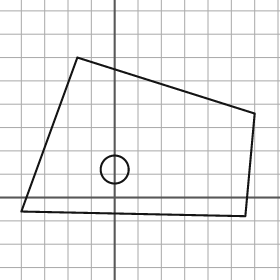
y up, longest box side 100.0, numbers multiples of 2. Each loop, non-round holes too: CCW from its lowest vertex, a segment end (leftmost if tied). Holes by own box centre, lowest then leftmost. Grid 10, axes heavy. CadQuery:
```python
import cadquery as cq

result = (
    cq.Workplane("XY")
    .moveTo(56.0, -8.0)
    .lineTo(60.0, 36.0)
    .lineTo(-16.0, 60.0)
    .lineTo(-40.0, -6.0)
    .close()
    .moveTo(0.0, 12.0)
    .circle(6.0)
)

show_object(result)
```